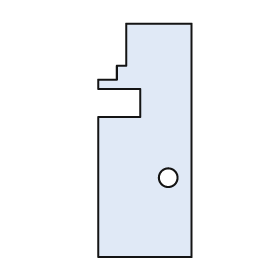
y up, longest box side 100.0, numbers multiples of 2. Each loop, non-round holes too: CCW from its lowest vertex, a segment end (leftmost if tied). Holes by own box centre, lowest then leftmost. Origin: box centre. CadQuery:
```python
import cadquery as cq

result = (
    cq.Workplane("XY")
    .moveTo(-20.0, -50.0)
    .lineTo(20.0, -50.0)
    .lineTo(20.0, 50.0)
    .lineTo(-8.0, 50.0)
    .lineTo(-8.0, 32.0)
    .lineTo(-12.0, 32.0)
    .lineTo(-12.0, 26.0)
    .lineTo(-20.0, 26.0)
    .lineTo(-20.0, 22.0)
    .lineTo(-2.0, 22.0)
    .lineTo(-2.0, 10.0)
    .lineTo(-20.0, 10.0)
    .close()
    .moveTo(10.0, -16.0)
    .circle(4.0)
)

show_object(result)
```